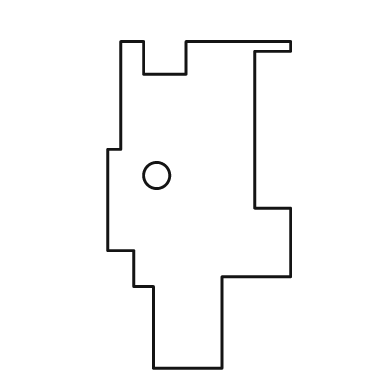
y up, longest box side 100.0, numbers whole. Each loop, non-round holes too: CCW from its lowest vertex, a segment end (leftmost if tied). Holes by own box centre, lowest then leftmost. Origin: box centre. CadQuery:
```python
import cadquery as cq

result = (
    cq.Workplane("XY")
    .moveTo(-14.0, -50.0)
    .lineTo(7.0, -50.0)
    .lineTo(7.0, -22.0)
    .lineTo(28.0, -22.0)
    .lineTo(28.0, -1.0)
    .lineTo(17.0, -1.0)
    .lineTo(17.0, 47.0)
    .lineTo(28.0, 47.0)
    .lineTo(28.0, 50.0)
    .lineTo(-4.0, 50.0)
    .lineTo(-4.0, 40.0)
    .lineTo(-17.0, 40.0)
    .lineTo(-17.0, 50.0)
    .lineTo(-24.0, 50.0)
    .lineTo(-24.0, 17.0)
    .lineTo(-28.0, 17.0)
    .lineTo(-28.0, -14.0)
    .lineTo(-20.0, -14.0)
    .lineTo(-20.0, -25.0)
    .lineTo(-14.0, -25.0)
    .close()
    .moveTo(-13.0, 9.0)
    .circle(4.0)
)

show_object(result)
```